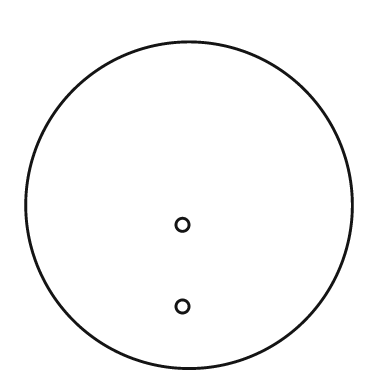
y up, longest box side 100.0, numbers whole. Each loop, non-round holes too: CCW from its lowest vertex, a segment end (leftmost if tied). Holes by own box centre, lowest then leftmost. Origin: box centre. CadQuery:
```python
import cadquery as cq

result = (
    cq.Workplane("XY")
    .moveTo(0.0, 0.0)
    .circle(50.0)
    .moveTo(-2.0, -31.0)
    .circle(2.0)
    .moveTo(-2.0, -6.0)
    .circle(2.0)
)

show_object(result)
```